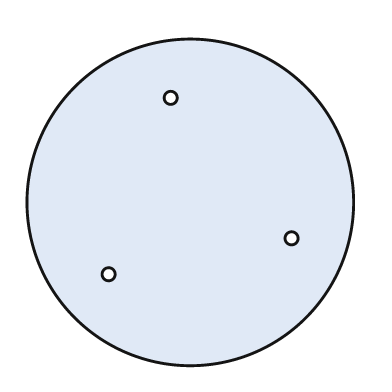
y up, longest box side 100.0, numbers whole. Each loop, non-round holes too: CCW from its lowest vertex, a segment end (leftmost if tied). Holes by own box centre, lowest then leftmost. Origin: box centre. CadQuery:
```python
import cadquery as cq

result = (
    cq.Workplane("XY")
    .moveTo(0.0, 0.0)
    .circle(50.0)
    .moveTo(-25.0, -22.0)
    .circle(2.0)
    .moveTo(31.0, -11.0)
    .circle(2.0)
    .moveTo(-6.0, 32.0)
    .circle(2.0)
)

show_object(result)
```